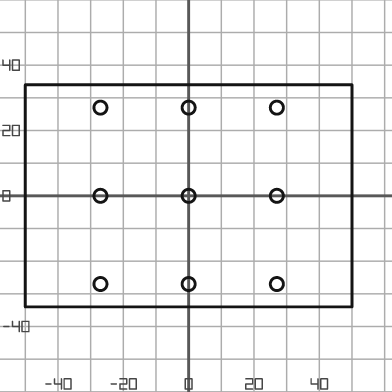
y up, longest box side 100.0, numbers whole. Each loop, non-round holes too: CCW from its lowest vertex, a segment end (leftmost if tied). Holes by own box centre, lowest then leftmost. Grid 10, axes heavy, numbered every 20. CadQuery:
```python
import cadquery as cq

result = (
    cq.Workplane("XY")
    .moveTo(-50.0, -34.0)
    .lineTo(50.0, -34.0)
    .lineTo(50.0, 34.0)
    .lineTo(-50.0, 34.0)
    .close()
    .moveTo(-27.0, -27.0)
    .circle(2.0)
    .moveTo(0.0, -27.0)
    .circle(2.0)
    .moveTo(27.0, -27.0)
    .circle(2.0)
    .moveTo(-27.0, 0.0)
    .circle(2.0)
    .moveTo(0.0, 0.0)
    .circle(2.0)
    .moveTo(27.0, 0.0)
    .circle(2.0)
    .moveTo(-27.0, 27.0)
    .circle(2.0)
    .moveTo(0.0, 27.0)
    .circle(2.0)
    .moveTo(27.0, 27.0)
    .circle(2.0)
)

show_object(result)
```